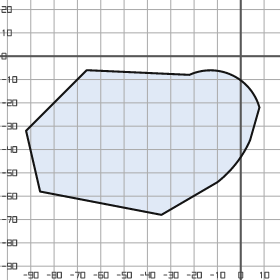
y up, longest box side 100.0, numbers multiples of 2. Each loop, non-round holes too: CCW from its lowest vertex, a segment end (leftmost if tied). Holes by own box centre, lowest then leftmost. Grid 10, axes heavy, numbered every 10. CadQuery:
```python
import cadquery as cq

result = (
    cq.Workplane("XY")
    .moveTo(-34.0, -68.0)
    .lineTo(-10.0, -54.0)
    .threePointArc((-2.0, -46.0), (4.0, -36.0))
    .lineTo(8.0, -22.0)
    .threePointArc((-4.0, -8.0), (-22.0, -8.0))
    .lineTo(-66.0, -6.0)
    .lineTo(-92.0, -32.0)
    .lineTo(-86.0, -58.0)
    .close()
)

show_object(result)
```